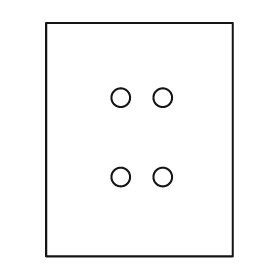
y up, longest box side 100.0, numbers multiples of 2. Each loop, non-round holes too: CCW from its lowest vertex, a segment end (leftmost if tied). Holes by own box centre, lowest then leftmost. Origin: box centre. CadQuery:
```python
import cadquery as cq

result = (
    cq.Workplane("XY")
    .moveTo(-40.0, -50.0)
    .lineTo(40.0, -50.0)
    .lineTo(40.0, 50.0)
    .lineTo(-40.0, 50.0)
    .close()
    .moveTo(-8.0, -16.0)
    .circle(4.0)
    .moveTo(10.0, -16.0)
    .circle(4.0)
    .moveTo(-8.0, 18.0)
    .circle(4.0)
    .moveTo(10.0, 18.0)
    .circle(4.0)
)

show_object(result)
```